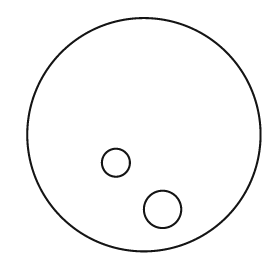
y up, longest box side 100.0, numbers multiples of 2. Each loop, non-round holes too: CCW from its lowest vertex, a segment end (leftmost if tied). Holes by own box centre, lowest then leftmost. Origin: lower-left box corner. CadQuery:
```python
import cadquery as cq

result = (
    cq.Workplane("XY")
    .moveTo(50.0, 50.0)
    .circle(50.0)
    .moveTo(58.0, 18.0)
    .circle(8.0)
    .moveTo(38.0, 38.0)
    .circle(6.0)
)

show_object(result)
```